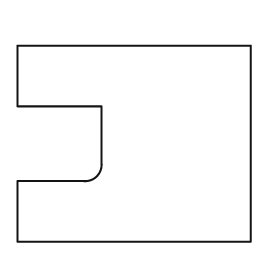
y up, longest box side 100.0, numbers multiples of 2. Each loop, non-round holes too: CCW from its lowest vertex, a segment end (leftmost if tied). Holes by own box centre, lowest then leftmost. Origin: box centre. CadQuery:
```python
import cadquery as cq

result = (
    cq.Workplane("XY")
    .moveTo(-50.0, -42.0)
    .lineTo(50.0, -42.0)
    .lineTo(50.0, 42.0)
    .lineTo(-50.0, 42.0)
    .lineTo(-50.0, 16.0)
    .lineTo(-14.0, 16.0)
    .lineTo(-14.0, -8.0)
    .threePointArc((-16.0, -14.0), (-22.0, -16.0))
    .lineTo(-50.0, -16.0)
    .close()
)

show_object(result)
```